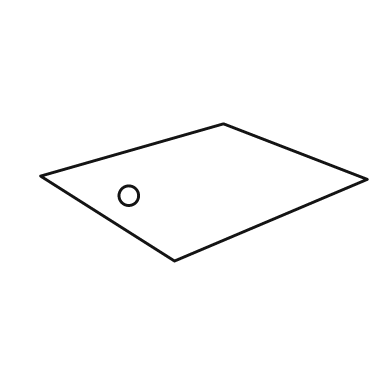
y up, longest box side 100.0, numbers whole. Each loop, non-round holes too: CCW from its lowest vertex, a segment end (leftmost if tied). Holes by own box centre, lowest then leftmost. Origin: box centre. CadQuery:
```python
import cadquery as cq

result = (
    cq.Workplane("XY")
    .moveTo(-9.0, -21.0)
    .lineTo(50.0, 4.0)
    .lineTo(6.0, 21.0)
    .lineTo(-50.0, 5.0)
    .close()
    .moveTo(-23.0, -1.0)
    .circle(3.0)
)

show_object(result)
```